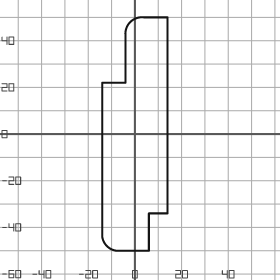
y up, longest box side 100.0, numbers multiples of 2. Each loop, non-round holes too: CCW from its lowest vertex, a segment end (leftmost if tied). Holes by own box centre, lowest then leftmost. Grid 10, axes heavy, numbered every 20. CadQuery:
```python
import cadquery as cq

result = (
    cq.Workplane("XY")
    .moveTo(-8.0, -50.0)
    .lineTo(6.0, -50.0)
    .lineTo(6.0, -34.0)
    .lineTo(14.0, -34.0)
    .lineTo(14.0, 50.0)
    .lineTo(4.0, 50.0)
    .threePointArc((-2.0, 48.0), (-4.0, 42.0))
    .lineTo(-4.0, 22.0)
    .lineTo(-14.0, 22.0)
    .lineTo(-14.0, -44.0)
    .threePointArc((-12.0, -48.0), (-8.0, -50.0))
    .close()
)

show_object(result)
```